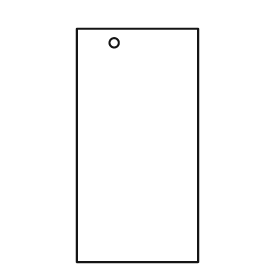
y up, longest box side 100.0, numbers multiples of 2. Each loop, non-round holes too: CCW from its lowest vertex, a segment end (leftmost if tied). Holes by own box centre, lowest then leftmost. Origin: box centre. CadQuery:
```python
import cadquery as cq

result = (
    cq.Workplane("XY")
    .moveTo(-26.0, -50.0)
    .lineTo(26.0, -50.0)
    .lineTo(26.0, 50.0)
    .lineTo(-26.0, 50.0)
    .close()
    .moveTo(-10.0, 44.0)
    .circle(2.0)
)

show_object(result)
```